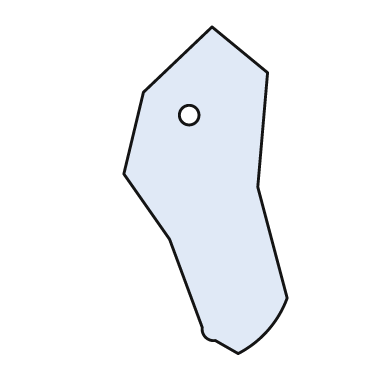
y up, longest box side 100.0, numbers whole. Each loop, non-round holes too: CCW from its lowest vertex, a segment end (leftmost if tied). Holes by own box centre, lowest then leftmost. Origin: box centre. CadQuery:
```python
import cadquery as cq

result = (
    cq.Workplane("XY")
    .moveTo(10.0, -50.0)
    .threePointArc((19.0, -43.0), (25.0, -33.0))
    .lineTo(16.0, 1.0)
    .lineTo(19.0, 36.0)
    .lineTo(2.0, 50.0)
    .lineTo(-19.0, 30.0)
    .lineTo(-25.0, 5.0)
    .lineTo(-11.0, -15.0)
    .lineTo(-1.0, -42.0)
    .threePointArc((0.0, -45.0), (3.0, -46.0))
    .close()
    .moveTo(-5.0, 23.0)
    .circle(3.0)
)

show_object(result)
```